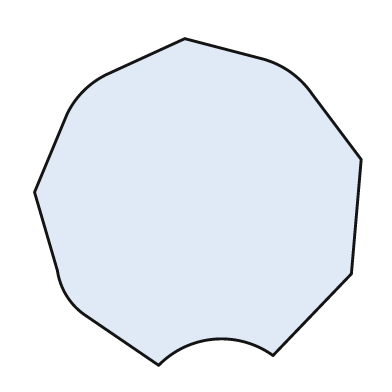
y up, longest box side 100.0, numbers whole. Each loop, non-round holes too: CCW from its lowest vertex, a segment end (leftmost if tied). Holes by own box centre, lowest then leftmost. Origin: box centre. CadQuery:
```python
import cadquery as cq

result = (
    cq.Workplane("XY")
    .moveTo(-12.0, -50.0)
    .threePointArc((5.0, -42.0), (23.0, -47.0))
    .lineTo(47.0, -22.0)
    .lineTo(50.0, 13.0)
    .lineTo(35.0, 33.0)
    .threePointArc((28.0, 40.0), (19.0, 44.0))
    .lineTo(-4.0, 50.0)
    .lineTo(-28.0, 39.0)
    .threePointArc((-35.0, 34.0), (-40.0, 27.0))
    .lineTo(-50.0, 3.0)
    .lineTo(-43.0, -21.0)
    .threePointArc((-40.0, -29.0), (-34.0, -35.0))
    .close()
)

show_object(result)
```